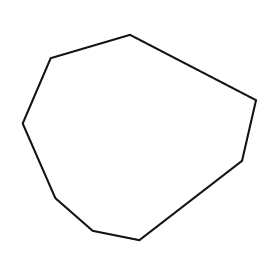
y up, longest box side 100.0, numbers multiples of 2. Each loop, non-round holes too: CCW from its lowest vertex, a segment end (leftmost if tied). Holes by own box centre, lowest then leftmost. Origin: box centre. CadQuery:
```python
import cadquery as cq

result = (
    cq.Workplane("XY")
    .moveTo(0.0, -44.0)
    .lineTo(44.0, -10.0)
    .lineTo(50.0, 16.0)
    .lineTo(-4.0, 44.0)
    .lineTo(-38.0, 34.0)
    .lineTo(-50.0, 6.0)
    .lineTo(-36.0, -26.0)
    .lineTo(-20.0, -40.0)
    .close()
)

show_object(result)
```